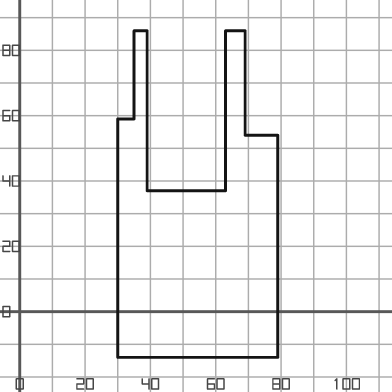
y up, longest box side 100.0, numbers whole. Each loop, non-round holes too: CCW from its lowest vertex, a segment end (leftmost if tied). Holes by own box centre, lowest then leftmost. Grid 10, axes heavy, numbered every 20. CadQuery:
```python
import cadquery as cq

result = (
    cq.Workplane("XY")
    .moveTo(30.0, -14.0)
    .lineTo(79.0, -14.0)
    .lineTo(79.0, 54.0)
    .lineTo(69.0, 54.0)
    .lineTo(69.0, 86.0)
    .lineTo(63.0, 86.0)
    .lineTo(63.0, 37.0)
    .lineTo(39.0, 37.0)
    .lineTo(39.0, 86.0)
    .lineTo(35.0, 86.0)
    .lineTo(35.0, 59.0)
    .lineTo(30.0, 59.0)
    .close()
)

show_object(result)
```